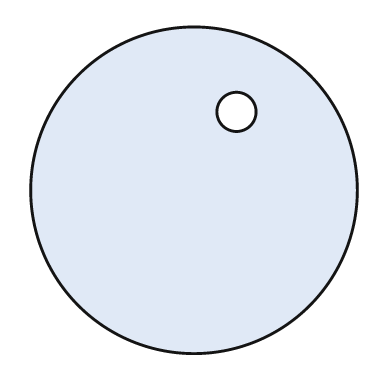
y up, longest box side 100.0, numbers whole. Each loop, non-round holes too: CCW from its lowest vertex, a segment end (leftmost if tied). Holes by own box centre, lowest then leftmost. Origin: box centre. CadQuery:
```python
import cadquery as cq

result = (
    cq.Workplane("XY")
    .moveTo(0.0, 0.0)
    .circle(50.0)
    .moveTo(13.0, 24.0)
    .circle(6.0)
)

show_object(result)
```